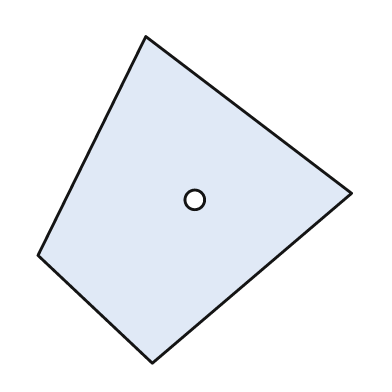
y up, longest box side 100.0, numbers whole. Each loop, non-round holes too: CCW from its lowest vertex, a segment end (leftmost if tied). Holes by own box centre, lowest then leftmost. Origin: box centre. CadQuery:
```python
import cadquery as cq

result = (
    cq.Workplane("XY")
    .moveTo(-13.0, -50.0)
    .lineTo(48.0, 2.0)
    .lineTo(-15.0, 50.0)
    .lineTo(-48.0, -17.0)
    .close()
    .moveTo(0.0, 0.0)
    .circle(3.0)
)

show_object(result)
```